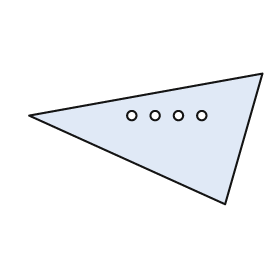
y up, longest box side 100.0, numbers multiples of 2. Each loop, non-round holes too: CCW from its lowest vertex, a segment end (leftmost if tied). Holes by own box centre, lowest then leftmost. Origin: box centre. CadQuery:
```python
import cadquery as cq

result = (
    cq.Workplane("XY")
    .moveTo(34.0, -28.0)
    .lineTo(50.0, 28.0)
    .lineTo(-50.0, 10.0)
    .close()
    .moveTo(-6.0, 10.0)
    .circle(2.0)
    .moveTo(4.0, 10.0)
    .circle(2.0)
    .moveTo(14.0, 10.0)
    .circle(2.0)
    .moveTo(24.0, 10.0)
    .circle(2.0)
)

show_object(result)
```